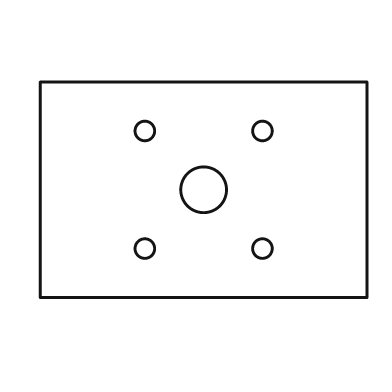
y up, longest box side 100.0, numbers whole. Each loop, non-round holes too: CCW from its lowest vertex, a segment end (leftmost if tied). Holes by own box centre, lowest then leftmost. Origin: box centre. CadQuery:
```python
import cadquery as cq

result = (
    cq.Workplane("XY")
    .moveTo(-50.0, -33.0)
    .lineTo(50.0, -33.0)
    .lineTo(50.0, 33.0)
    .lineTo(-50.0, 33.0)
    .close()
    .moveTo(-18.0, -18.0)
    .circle(3.0)
    .moveTo(18.0, -18.0)
    .circle(3.0)
    .moveTo(0.0, 0.0)
    .circle(7.0)
    .moveTo(-18.0, 18.0)
    .circle(3.0)
    .moveTo(18.0, 18.0)
    .circle(3.0)
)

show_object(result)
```